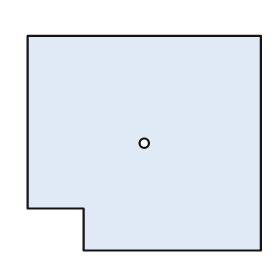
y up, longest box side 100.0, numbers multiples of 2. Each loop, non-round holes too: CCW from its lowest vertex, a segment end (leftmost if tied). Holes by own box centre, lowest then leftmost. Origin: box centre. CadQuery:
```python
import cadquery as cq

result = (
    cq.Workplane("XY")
    .moveTo(-26.0, -46.0)
    .lineTo(50.0, -46.0)
    .lineTo(50.0, 46.0)
    .lineTo(-50.0, 46.0)
    .lineTo(-50.0, -28.0)
    .lineTo(-26.0, -28.0)
    .close()
    .moveTo(0.0, 0.0)
    .circle(2.0)
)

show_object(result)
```